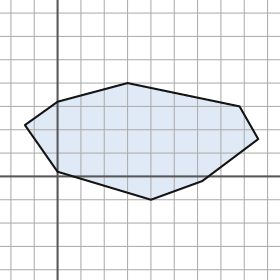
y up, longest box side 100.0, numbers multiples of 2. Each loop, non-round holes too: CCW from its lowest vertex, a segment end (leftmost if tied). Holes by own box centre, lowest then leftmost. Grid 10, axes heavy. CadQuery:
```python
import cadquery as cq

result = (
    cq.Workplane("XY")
    .moveTo(40.0, -10.0)
    .lineTo(62.0, -2.0)
    .lineTo(86.0, 16.0)
    .lineTo(78.0, 30.0)
    .lineTo(30.0, 40.0)
    .lineTo(0.0, 32.0)
    .lineTo(-14.0, 22.0)
    .lineTo(0.0, 2.0)
    .close()
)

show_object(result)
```